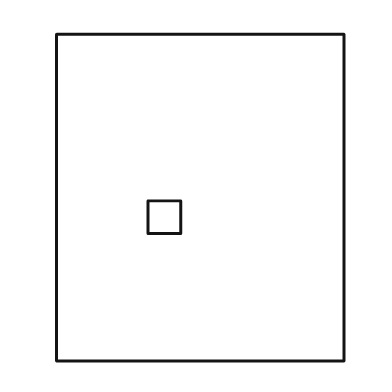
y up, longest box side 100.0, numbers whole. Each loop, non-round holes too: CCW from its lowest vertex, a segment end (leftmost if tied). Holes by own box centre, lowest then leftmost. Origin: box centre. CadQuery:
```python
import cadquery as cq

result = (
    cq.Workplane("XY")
    .moveTo(-44.0, -50.0)
    .lineTo(44.0, -50.0)
    .lineTo(44.0, 50.0)
    .lineTo(-44.0, 50.0)
    .close()
    .moveTo(-16.0, -11.0)
    .lineTo(-6.0, -11.0)
    .lineTo(-6.0, -1.0)
    .lineTo(-16.0, -1.0)
    .close()
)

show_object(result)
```